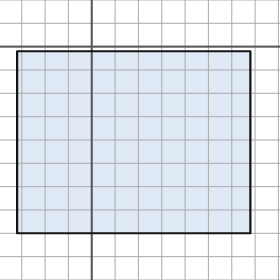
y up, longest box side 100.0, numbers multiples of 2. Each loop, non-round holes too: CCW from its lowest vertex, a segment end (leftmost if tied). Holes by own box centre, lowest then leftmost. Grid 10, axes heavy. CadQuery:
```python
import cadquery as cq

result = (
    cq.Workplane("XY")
    .moveTo(-32.0, -80.0)
    .lineTo(68.0, -80.0)
    .lineTo(68.0, -2.0)
    .lineTo(-32.0, -2.0)
    .close()
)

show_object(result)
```